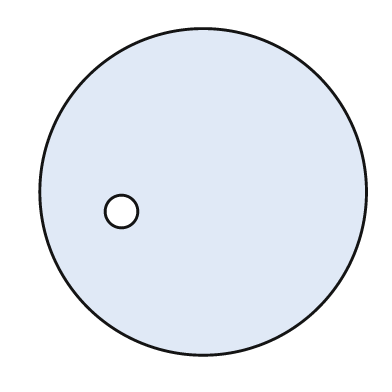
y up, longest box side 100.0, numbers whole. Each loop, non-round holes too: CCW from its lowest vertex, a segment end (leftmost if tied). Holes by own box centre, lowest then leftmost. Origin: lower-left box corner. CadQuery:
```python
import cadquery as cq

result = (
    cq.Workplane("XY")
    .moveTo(50.0, 50.0)
    .circle(50.0)
    .moveTo(25.0, 44.0)
    .circle(5.0)
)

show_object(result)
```